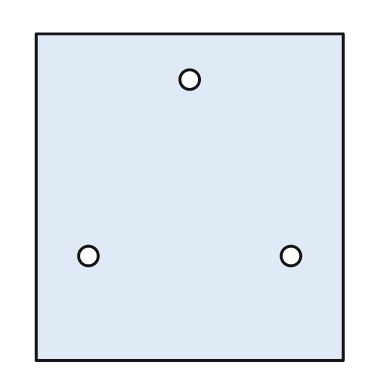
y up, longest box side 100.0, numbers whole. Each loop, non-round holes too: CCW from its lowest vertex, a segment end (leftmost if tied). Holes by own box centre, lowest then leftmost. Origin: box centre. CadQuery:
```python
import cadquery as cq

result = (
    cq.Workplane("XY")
    .moveTo(-47.0, -50.0)
    .lineTo(47.0, -50.0)
    .lineTo(47.0, 50.0)
    .lineTo(-47.0, 50.0)
    .close()
    .moveTo(-31.0, -18.0)
    .circle(3.0)
    .moveTo(31.0, -18.0)
    .circle(3.0)
    .moveTo(0.0, 36.0)
    .circle(3.0)
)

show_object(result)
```